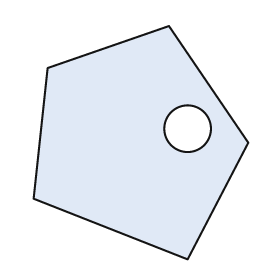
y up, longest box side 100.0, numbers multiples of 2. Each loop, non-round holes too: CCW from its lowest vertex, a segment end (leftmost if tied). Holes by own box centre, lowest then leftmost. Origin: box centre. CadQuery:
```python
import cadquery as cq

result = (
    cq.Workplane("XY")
    .moveTo(20.0, -50.0)
    .lineTo(46.0, 0.0)
    .lineTo(12.0, 50.0)
    .lineTo(-40.0, 32.0)
    .lineTo(-46.0, -24.0)
    .close()
    .moveTo(20.0, 6.0)
    .circle(10.0)
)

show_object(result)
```